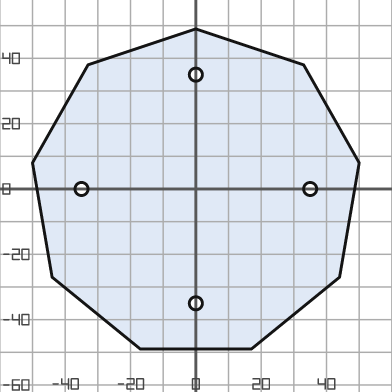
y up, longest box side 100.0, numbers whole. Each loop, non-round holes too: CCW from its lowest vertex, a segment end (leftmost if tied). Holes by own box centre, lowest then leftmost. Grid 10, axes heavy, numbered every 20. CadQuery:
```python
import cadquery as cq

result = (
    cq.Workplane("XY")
    .moveTo(-17.0, -49.0)
    .lineTo(17.0, -49.0)
    .lineTo(44.0, -27.0)
    .lineTo(50.0, 8.0)
    .lineTo(33.0, 38.0)
    .lineTo(0.0, 49.0)
    .lineTo(-33.0, 38.0)
    .lineTo(-50.0, 8.0)
    .lineTo(-44.0, -27.0)
    .close()
    .moveTo(0.0, -35.0)
    .circle(2.0)
    .moveTo(-35.0, 0.0)
    .circle(2.0)
    .moveTo(35.0, 0.0)
    .circle(2.0)
    .moveTo(0.0, 35.0)
    .circle(2.0)
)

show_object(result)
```